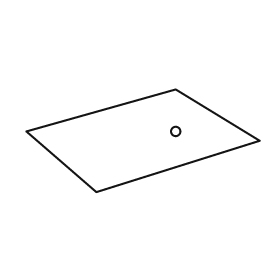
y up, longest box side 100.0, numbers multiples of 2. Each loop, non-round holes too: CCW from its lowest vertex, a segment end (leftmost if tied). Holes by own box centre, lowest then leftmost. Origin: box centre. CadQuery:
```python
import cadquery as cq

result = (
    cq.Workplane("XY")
    .moveTo(-20.0, -22.0)
    .lineTo(50.0, 0.0)
    .lineTo(14.0, 22.0)
    .lineTo(-50.0, 4.0)
    .close()
    .moveTo(14.0, 4.0)
    .circle(2.0)
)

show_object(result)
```